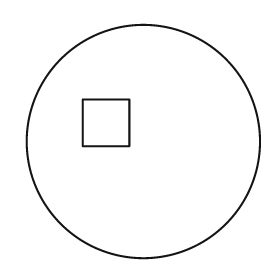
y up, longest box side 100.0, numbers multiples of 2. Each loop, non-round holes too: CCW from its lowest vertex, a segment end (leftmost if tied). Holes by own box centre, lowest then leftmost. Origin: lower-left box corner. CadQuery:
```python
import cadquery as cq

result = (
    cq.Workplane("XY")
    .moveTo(50.0, 50.0)
    .circle(50.0)
    .moveTo(24.0, 48.0)
    .lineTo(44.0, 48.0)
    .lineTo(44.0, 68.0)
    .lineTo(24.0, 68.0)
    .close()
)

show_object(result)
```